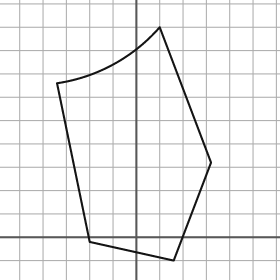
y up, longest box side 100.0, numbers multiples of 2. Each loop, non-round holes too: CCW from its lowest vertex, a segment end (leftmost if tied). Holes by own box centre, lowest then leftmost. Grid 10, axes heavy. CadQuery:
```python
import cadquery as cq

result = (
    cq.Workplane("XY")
    .moveTo(16.0, -10.0)
    .lineTo(32.0, 32.0)
    .lineTo(10.0, 90.0)
    .threePointArc((-10.0, 74.0), (-34.0, 66.0))
    .lineTo(-20.0, -2.0)
    .close()
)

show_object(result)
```